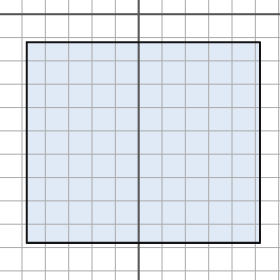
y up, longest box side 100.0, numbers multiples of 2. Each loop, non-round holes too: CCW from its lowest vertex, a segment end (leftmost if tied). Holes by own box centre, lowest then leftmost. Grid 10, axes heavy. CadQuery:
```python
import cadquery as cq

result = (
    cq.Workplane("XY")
    .moveTo(-48.0, -98.0)
    .lineTo(52.0, -98.0)
    .lineTo(52.0, -12.0)
    .lineTo(-48.0, -12.0)
    .close()
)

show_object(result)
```